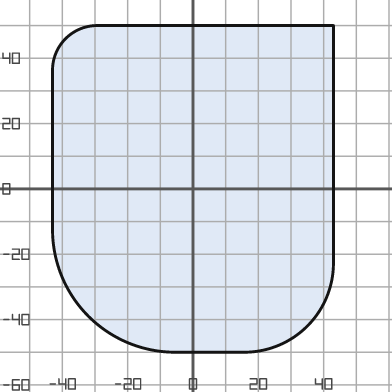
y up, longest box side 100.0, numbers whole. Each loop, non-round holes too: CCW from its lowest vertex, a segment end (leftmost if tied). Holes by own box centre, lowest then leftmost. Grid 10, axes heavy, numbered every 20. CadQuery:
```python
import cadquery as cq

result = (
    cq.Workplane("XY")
    .moveTo(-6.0, -50.0)
    .lineTo(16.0, -50.0)
    .threePointArc((35.0, -42.0), (43.0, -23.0))
    .lineTo(43.0, 50.0)
    .lineTo(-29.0, 50.0)
    .threePointArc((-39.0, 46.0), (-43.0, 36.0))
    .lineTo(-43.0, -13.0)
    .threePointArc((-32.0, -39.0), (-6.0, -50.0))
    .close()
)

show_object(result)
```